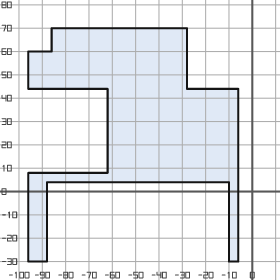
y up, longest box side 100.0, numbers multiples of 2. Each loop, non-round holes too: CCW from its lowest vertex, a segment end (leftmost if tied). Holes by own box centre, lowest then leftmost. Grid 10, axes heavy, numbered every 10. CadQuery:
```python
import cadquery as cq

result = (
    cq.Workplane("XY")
    .moveTo(-96.0, -30.0)
    .lineTo(-88.0, -30.0)
    .lineTo(-88.0, 4.0)
    .lineTo(-10.0, 4.0)
    .lineTo(-10.0, -30.0)
    .lineTo(-6.0, -30.0)
    .lineTo(-6.0, 44.0)
    .lineTo(-28.0, 44.0)
    .lineTo(-28.0, 70.0)
    .lineTo(-86.0, 70.0)
    .lineTo(-86.0, 60.0)
    .lineTo(-96.0, 60.0)
    .lineTo(-96.0, 44.0)
    .lineTo(-62.0, 44.0)
    .lineTo(-62.0, 8.0)
    .lineTo(-96.0, 8.0)
    .close()
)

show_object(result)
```